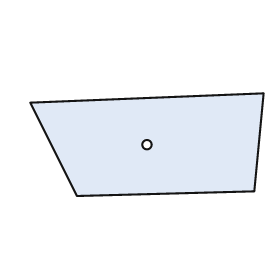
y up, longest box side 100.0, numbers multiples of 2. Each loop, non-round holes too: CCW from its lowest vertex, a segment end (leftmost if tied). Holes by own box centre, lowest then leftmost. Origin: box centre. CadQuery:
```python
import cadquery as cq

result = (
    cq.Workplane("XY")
    .moveTo(-30.0, -22.0)
    .lineTo(46.0, -20.0)
    .lineTo(50.0, 22.0)
    .lineTo(-50.0, 18.0)
    .close()
    .moveTo(0.0, 0.0)
    .circle(2.0)
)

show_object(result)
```